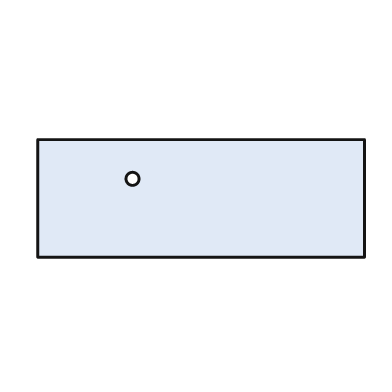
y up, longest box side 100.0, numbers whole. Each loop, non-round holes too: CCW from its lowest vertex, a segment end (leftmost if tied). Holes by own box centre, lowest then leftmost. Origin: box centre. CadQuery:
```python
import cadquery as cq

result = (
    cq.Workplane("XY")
    .moveTo(-50.0, -18.0)
    .lineTo(50.0, -18.0)
    .lineTo(50.0, 18.0)
    .lineTo(-50.0, 18.0)
    .close()
    .moveTo(-21.0, 6.0)
    .circle(2.0)
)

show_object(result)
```